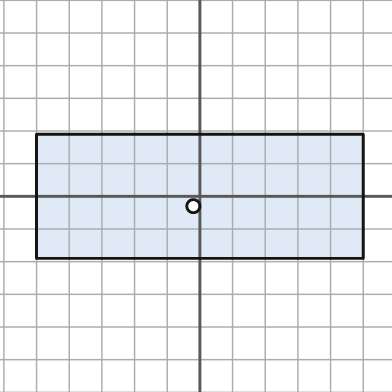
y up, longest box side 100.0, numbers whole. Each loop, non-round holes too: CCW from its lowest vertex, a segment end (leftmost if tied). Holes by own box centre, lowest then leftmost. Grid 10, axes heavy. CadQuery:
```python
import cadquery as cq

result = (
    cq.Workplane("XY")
    .moveTo(-50.0, -19.0)
    .lineTo(50.0, -19.0)
    .lineTo(50.0, 19.0)
    .lineTo(-50.0, 19.0)
    .close()
    .moveTo(-2.0, -3.0)
    .circle(2.0)
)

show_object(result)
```